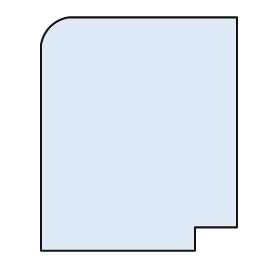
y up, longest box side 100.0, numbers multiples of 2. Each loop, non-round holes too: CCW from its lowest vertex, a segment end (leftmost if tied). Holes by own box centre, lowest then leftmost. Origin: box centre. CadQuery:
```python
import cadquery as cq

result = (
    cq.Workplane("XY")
    .moveTo(-42.0, -50.0)
    .lineTo(24.0, -50.0)
    .lineTo(24.0, -40.0)
    .lineTo(42.0, -40.0)
    .lineTo(42.0, 50.0)
    .lineTo(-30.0, 50.0)
    .threePointArc((-38.0, 46.0), (-42.0, 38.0))
    .close()
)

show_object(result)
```